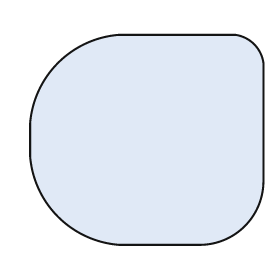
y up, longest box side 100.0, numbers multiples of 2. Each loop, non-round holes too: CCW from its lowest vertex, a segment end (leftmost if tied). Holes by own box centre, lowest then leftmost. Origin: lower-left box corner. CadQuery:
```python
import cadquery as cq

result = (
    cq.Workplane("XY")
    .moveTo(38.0, 0.0)
    .lineTo(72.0, 0.0)
    .threePointArc((92.0, 8.0), (100.0, 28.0))
    .lineTo(100.0, 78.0)
    .threePointArc((96.0, 86.0), (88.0, 90.0))
    .lineTo(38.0, 90.0)
    .threePointArc((12.0, 78.0), (0.0, 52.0))
    .lineTo(0.0, 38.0)
    .threePointArc((12.0, 12.0), (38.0, 0.0))
    .close()
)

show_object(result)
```